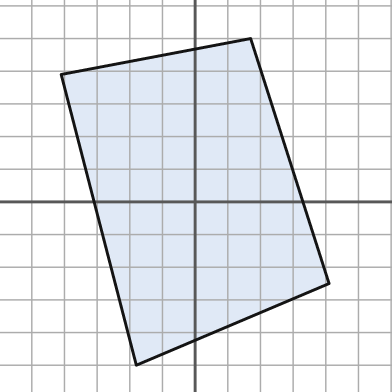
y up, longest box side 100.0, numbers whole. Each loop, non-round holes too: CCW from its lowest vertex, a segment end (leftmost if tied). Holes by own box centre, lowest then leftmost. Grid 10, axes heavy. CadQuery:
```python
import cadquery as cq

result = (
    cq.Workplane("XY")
    .moveTo(-18.0, -50.0)
    .lineTo(41.0, -25.0)
    .lineTo(17.0, 50.0)
    .lineTo(-41.0, 39.0)
    .close()
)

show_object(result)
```